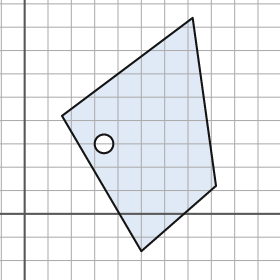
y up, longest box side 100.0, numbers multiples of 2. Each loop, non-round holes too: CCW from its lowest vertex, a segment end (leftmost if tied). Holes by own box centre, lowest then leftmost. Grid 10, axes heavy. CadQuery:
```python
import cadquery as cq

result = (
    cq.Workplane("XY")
    .moveTo(50.0, -16.0)
    .lineTo(82.0, 12.0)
    .lineTo(72.0, 84.0)
    .lineTo(16.0, 42.0)
    .close()
    .moveTo(34.0, 30.0)
    .circle(4.0)
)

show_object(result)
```